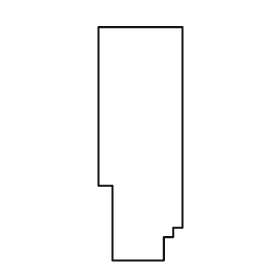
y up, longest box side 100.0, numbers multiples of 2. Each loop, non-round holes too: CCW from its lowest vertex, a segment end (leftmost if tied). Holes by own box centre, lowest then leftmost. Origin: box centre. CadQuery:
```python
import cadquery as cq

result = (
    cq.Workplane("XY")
    .moveTo(-12.0, -50.0)
    .lineTo(10.0, -50.0)
    .lineTo(10.0, -40.0)
    .lineTo(14.0, -40.0)
    .lineTo(14.0, -36.0)
    .lineTo(18.0, -36.0)
    .lineTo(18.0, 50.0)
    .lineTo(-18.0, 50.0)
    .lineTo(-18.0, -18.0)
    .lineTo(-12.0, -18.0)
    .close()
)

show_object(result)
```